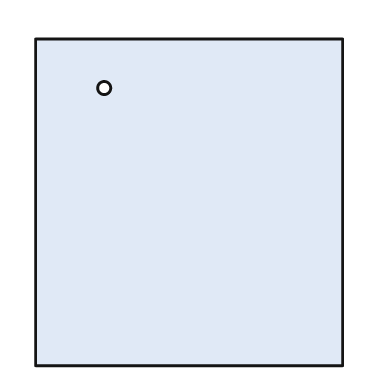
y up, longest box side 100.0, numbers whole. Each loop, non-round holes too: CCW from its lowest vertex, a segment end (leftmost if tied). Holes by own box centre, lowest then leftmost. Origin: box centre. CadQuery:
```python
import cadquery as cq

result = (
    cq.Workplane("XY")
    .moveTo(-47.0, -50.0)
    .lineTo(47.0, -50.0)
    .lineTo(47.0, 50.0)
    .lineTo(-47.0, 50.0)
    .close()
    .moveTo(-26.0, 35.0)
    .circle(2.0)
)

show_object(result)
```